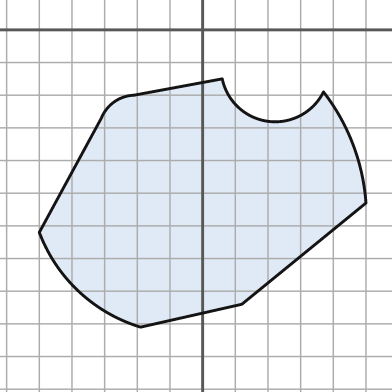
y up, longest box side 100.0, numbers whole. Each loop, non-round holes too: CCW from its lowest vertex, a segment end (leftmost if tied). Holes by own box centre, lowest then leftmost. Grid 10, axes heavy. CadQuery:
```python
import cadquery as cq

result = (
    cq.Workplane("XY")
    .moveTo(-19.0, -91.0)
    .lineTo(12.0, -84.0)
    .lineTo(50.0, -53.0)
    .threePointArc((46.0, -35.0), (37.0, -19.0))
    .threePointArc((20.0, -28.0), (6.0, -15.0))
    .lineTo(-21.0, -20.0)
    .threePointArc((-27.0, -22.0), (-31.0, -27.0))
    .lineTo(-50.0, -62.0)
    .threePointArc((-38.0, -80.0), (-19.0, -91.0))
    .close()
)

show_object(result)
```